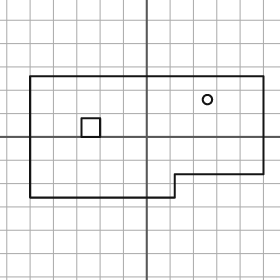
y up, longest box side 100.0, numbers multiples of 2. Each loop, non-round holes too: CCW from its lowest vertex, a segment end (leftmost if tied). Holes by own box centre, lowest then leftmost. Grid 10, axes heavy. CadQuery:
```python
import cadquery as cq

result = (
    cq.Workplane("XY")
    .moveTo(-50.0, -26.0)
    .lineTo(12.0, -26.0)
    .lineTo(12.0, -16.0)
    .lineTo(50.0, -16.0)
    .lineTo(50.0, 26.0)
    .lineTo(-50.0, 26.0)
    .close()
    .moveTo(-28.0, 0.0)
    .lineTo(-20.0, 0.0)
    .lineTo(-20.0, 8.0)
    .lineTo(-28.0, 8.0)
    .close()
    .moveTo(26.0, 16.0)
    .circle(2.0)
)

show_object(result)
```